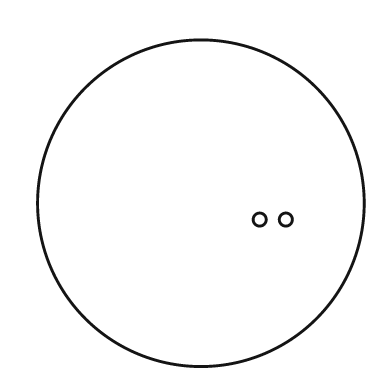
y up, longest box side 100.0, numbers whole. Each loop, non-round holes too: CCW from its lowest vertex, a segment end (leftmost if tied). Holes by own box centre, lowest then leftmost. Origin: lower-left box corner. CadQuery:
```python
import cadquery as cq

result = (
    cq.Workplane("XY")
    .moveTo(50.0, 50.0)
    .circle(50.0)
    .moveTo(68.0, 45.0)
    .circle(2.0)
    .moveTo(76.0, 45.0)
    .circle(2.0)
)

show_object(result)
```